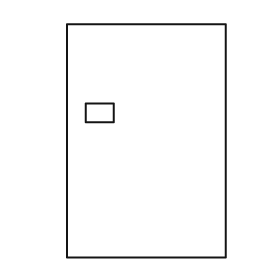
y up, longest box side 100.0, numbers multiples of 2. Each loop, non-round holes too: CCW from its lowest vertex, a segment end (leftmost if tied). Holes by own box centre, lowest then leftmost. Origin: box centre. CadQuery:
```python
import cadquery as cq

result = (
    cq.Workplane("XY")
    .moveTo(-34.0, -50.0)
    .lineTo(34.0, -50.0)
    .lineTo(34.0, 50.0)
    .lineTo(-34.0, 50.0)
    .close()
    .moveTo(-26.0, 8.0)
    .lineTo(-14.0, 8.0)
    .lineTo(-14.0, 16.0)
    .lineTo(-26.0, 16.0)
    .close()
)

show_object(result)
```